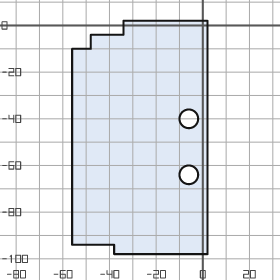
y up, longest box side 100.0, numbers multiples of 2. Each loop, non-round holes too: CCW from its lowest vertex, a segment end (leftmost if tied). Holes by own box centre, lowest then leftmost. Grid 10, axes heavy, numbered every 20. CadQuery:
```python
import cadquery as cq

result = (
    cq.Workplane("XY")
    .moveTo(-38.0, -98.0)
    .lineTo(2.0, -98.0)
    .lineTo(2.0, 2.0)
    .lineTo(-34.0, 2.0)
    .lineTo(-34.0, -4.0)
    .lineTo(-48.0, -4.0)
    .lineTo(-48.0, -10.0)
    .lineTo(-56.0, -10.0)
    .lineTo(-56.0, -94.0)
    .lineTo(-38.0, -94.0)
    .close()
    .moveTo(-6.0, -64.0)
    .circle(4.0)
    .moveTo(-6.0, -40.0)
    .circle(4.0)
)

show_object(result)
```